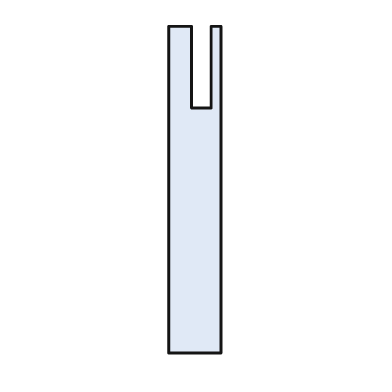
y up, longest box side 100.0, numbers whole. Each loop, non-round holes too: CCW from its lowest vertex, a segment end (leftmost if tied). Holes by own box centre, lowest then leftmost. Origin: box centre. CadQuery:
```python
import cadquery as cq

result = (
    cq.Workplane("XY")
    .moveTo(-8.0, -50.0)
    .lineTo(8.0, -50.0)
    .lineTo(8.0, 50.0)
    .lineTo(5.0, 50.0)
    .lineTo(5.0, 25.0)
    .lineTo(-1.0, 25.0)
    .lineTo(-1.0, 50.0)
    .lineTo(-8.0, 50.0)
    .close()
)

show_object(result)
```